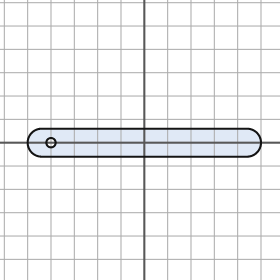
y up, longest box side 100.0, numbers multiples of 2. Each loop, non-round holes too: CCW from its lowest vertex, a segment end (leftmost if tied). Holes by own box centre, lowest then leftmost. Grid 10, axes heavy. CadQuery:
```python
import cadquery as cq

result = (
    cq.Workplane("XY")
    .moveTo(-44.0, -6.0)
    .lineTo(44.0, -6.0)
    .threePointArc((50.0, 0.0), (44.0, 6.0))
    .lineTo(-44.0, 6.0)
    .threePointArc((-50.0, 0.0), (-44.0, -6.0))
    .close()
    .moveTo(-40.0, 0.0)
    .circle(2.0)
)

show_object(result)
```